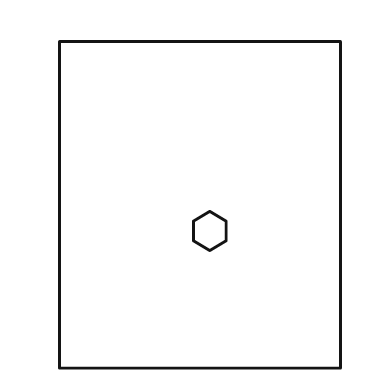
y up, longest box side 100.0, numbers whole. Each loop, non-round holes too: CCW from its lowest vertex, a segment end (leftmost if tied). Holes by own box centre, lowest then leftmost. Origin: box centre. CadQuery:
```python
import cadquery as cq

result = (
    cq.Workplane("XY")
    .moveTo(-43.0, -50.0)
    .lineTo(43.0, -50.0)
    .lineTo(43.0, 50.0)
    .lineTo(-43.0, 50.0)
    .close()
    .moveTo(3.0, -14.0)
    .lineTo(8.0, -11.0)
    .lineTo(8.0, -5.0)
    .lineTo(3.0, -2.0)
    .lineTo(-2.0, -5.0)
    .lineTo(-2.0, -11.0)
    .close()
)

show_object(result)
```